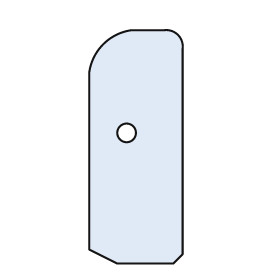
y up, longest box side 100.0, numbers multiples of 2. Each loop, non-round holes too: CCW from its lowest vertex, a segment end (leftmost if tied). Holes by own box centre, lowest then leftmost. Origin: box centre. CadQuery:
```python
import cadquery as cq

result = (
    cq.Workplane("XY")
    .moveTo(-8.0, -50.0)
    .lineTo(16.0, -50.0)
    .lineTo(20.0, -46.0)
    .lineTo(20.0, 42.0)
    .threePointArc((18.0, 48.0), (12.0, 50.0))
    .lineTo(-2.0, 50.0)
    .threePointArc((-14.0, 44.0), (-20.0, 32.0))
    .lineTo(-20.0, -44.0)
    .close()
    .moveTo(-4.0, 6.0)
    .circle(4.0)
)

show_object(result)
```